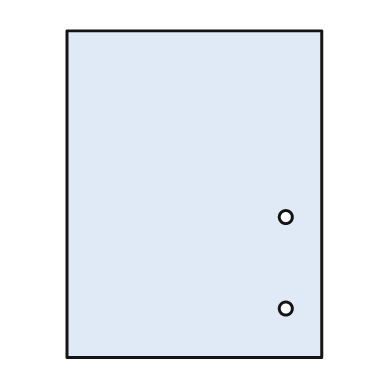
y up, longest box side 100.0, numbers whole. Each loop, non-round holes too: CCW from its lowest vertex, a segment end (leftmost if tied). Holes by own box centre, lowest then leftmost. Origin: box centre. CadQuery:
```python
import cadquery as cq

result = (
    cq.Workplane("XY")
    .moveTo(-39.0, -50.0)
    .lineTo(39.0, -50.0)
    .lineTo(39.0, 50.0)
    .lineTo(-39.0, 50.0)
    .close()
    .moveTo(28.0, -35.0)
    .circle(2.0)
    .moveTo(28.0, -7.0)
    .circle(2.0)
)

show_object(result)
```